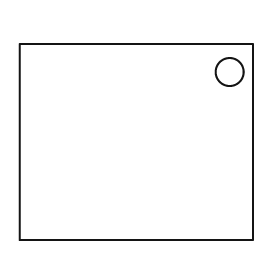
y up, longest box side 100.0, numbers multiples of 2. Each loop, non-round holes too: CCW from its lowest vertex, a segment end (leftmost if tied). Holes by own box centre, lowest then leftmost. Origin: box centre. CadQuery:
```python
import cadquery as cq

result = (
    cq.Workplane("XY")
    .moveTo(-50.0, -42.0)
    .lineTo(50.0, -42.0)
    .lineTo(50.0, 42.0)
    .lineTo(-50.0, 42.0)
    .close()
    .moveTo(40.0, 30.0)
    .circle(6.0)
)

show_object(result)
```